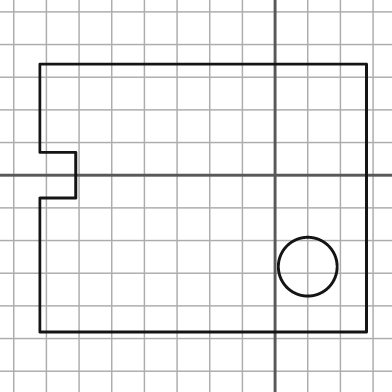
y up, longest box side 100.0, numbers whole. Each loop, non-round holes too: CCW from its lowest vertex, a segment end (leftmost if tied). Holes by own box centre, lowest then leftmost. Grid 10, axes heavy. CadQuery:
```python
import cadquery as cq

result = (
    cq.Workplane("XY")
    .moveTo(-72.0, -48.0)
    .lineTo(28.0, -48.0)
    .lineTo(28.0, 34.0)
    .lineTo(-72.0, 34.0)
    .lineTo(-72.0, 7.0)
    .lineTo(-61.0, 7.0)
    .lineTo(-61.0, -7.0)
    .lineTo(-72.0, -7.0)
    .close()
    .moveTo(10.0, -28.0)
    .circle(9.0)
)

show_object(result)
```